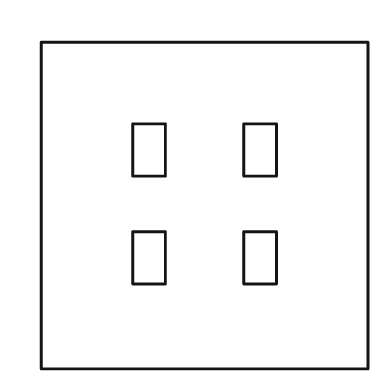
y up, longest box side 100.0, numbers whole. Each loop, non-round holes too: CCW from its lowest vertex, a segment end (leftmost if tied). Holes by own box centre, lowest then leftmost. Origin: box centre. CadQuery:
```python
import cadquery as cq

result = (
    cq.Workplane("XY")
    .moveTo(-50.0, -50.0)
    .lineTo(50.0, -50.0)
    .lineTo(50.0, 50.0)
    .lineTo(-50.0, 50.0)
    .close()
    .moveTo(-22.0, -24.0)
    .lineTo(-12.0, -24.0)
    .lineTo(-12.0, -8.0)
    .lineTo(-22.0, -8.0)
    .close()
    .moveTo(12.0, -24.0)
    .lineTo(22.0, -24.0)
    .lineTo(22.0, -8.0)
    .lineTo(12.0, -8.0)
    .close()
    .moveTo(-22.0, 9.0)
    .lineTo(-12.0, 9.0)
    .lineTo(-12.0, 25.0)
    .lineTo(-22.0, 25.0)
    .close()
    .moveTo(12.0, 9.0)
    .lineTo(22.0, 9.0)
    .lineTo(22.0, 25.0)
    .lineTo(12.0, 25.0)
    .close()
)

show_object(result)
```